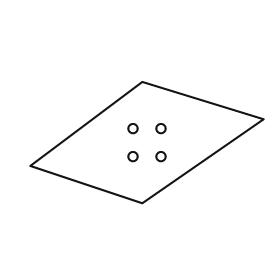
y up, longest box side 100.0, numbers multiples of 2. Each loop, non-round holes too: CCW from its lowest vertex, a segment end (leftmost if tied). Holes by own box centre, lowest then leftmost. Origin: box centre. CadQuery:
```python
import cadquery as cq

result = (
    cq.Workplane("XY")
    .moveTo(-2.0, -26.0)
    .lineTo(50.0, 10.0)
    .lineTo(-2.0, 26.0)
    .lineTo(-50.0, -10.0)
    .close()
    .moveTo(-6.0, -6.0)
    .circle(2.0)
    .moveTo(6.0, -6.0)
    .circle(2.0)
    .moveTo(-6.0, 6.0)
    .circle(2.0)
    .moveTo(6.0, 6.0)
    .circle(2.0)
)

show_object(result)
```